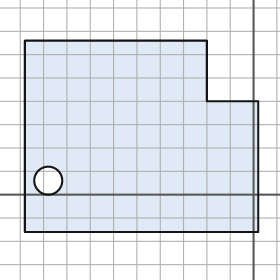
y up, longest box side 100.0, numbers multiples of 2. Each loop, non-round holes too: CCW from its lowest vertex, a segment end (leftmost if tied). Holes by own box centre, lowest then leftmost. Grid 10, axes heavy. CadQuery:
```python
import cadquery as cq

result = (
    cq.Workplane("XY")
    .moveTo(-98.0, -16.0)
    .lineTo(2.0, -16.0)
    .lineTo(2.0, 40.0)
    .lineTo(-20.0, 40.0)
    .lineTo(-20.0, 66.0)
    .lineTo(-98.0, 66.0)
    .close()
    .moveTo(-88.0, 6.0)
    .circle(6.0)
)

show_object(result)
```